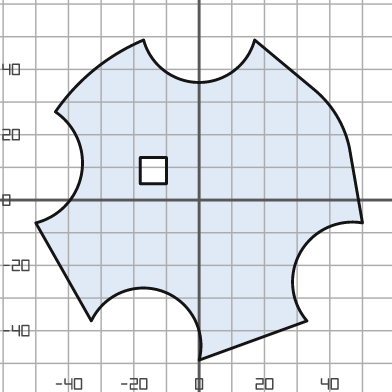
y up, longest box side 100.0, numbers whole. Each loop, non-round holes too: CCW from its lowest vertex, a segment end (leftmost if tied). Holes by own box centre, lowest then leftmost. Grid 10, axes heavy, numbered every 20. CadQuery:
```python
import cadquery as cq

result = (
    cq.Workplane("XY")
    .moveTo(0.0, -49.0)
    .lineTo(33.0, -37.0)
    .threePointArc((31.0, -16.0), (50.0, -7.0))
    .lineTo(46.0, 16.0)
    .threePointArc((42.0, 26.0), (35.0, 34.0))
    .lineTo(17.0, 49.0)
    .threePointArc((0.0, 36.0), (-17.0, 49.0))
    .threePointArc((-32.0, 40.0), (-44.0, 27.0))
    .threePointArc((-36.0, 8.0), (-50.0, -7.0))
    .lineTo(-33.0, -37.0)
    .threePointArc((-11.0, -28.0), (0.0, -49.0))
    .close()
    .moveTo(-18.0, 5.0)
    .lineTo(-10.0, 5.0)
    .lineTo(-10.0, 13.0)
    .lineTo(-18.0, 13.0)
    .close()
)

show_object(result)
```